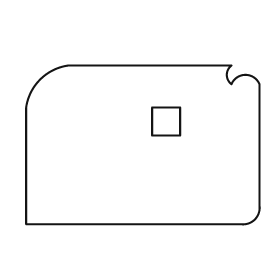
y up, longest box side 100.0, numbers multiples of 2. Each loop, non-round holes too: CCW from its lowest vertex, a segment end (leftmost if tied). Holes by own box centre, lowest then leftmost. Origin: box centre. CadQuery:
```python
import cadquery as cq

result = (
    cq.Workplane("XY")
    .moveTo(-50.0, -34.0)
    .lineTo(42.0, -34.0)
    .threePointArc((48.0, -32.0), (50.0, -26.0))
    .lineTo(50.0, 26.0)
    .threePointArc((44.0, 30.0), (38.0, 26.0))
    .threePointArc((36.0, 30.0), (38.0, 34.0))
    .lineTo(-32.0, 34.0)
    .threePointArc((-44.0, 28.0), (-50.0, 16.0))
    .close()
    .moveTo(4.0, 4.0)
    .lineTo(16.0, 4.0)
    .lineTo(16.0, 16.0)
    .lineTo(4.0, 16.0)
    .close()
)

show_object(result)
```